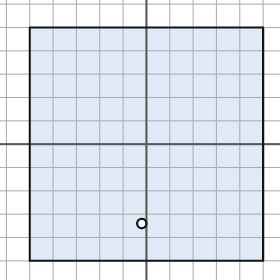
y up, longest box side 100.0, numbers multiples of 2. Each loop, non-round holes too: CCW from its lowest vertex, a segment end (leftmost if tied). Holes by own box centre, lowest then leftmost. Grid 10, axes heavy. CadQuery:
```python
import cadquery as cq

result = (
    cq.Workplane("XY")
    .moveTo(-50.0, -50.0)
    .lineTo(50.0, -50.0)
    .lineTo(50.0, 50.0)
    .lineTo(-50.0, 50.0)
    .close()
    .moveTo(-2.0, -34.0)
    .circle(2.0)
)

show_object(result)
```